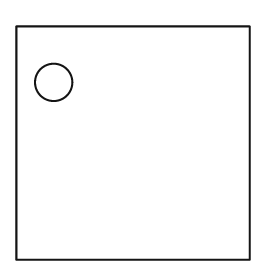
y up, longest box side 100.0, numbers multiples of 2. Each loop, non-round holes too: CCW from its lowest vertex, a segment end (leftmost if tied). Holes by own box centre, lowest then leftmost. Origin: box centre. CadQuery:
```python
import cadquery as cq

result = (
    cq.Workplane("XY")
    .moveTo(-50.0, -50.0)
    .lineTo(50.0, -50.0)
    .lineTo(50.0, 50.0)
    .lineTo(-50.0, 50.0)
    .close()
    .moveTo(-34.0, 26.0)
    .circle(8.0)
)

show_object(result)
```